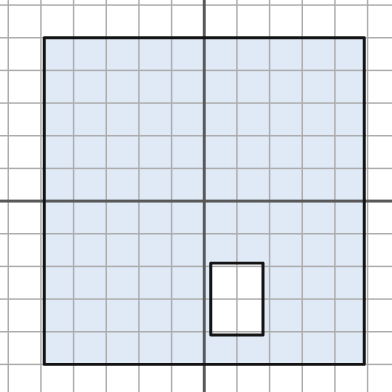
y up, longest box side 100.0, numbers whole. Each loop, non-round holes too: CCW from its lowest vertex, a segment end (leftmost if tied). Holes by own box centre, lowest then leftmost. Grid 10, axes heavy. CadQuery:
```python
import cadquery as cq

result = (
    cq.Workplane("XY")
    .moveTo(-49.0, -50.0)
    .lineTo(49.0, -50.0)
    .lineTo(49.0, 50.0)
    .lineTo(-49.0, 50.0)
    .close()
    .moveTo(2.0, -41.0)
    .lineTo(18.0, -41.0)
    .lineTo(18.0, -19.0)
    .lineTo(2.0, -19.0)
    .close()
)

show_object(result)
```